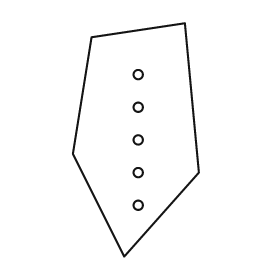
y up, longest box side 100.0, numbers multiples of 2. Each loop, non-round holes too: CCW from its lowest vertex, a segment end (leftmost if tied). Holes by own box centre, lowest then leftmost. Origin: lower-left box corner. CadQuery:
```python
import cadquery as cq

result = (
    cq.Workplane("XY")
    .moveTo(22.0, 0.0)
    .lineTo(54.0, 36.0)
    .lineTo(48.0, 100.0)
    .lineTo(8.0, 94.0)
    .lineTo(0.0, 44.0)
    .close()
    .moveTo(28.0, 22.0)
    .circle(2.0)
    .moveTo(28.0, 36.0)
    .circle(2.0)
    .moveTo(28.0, 50.0)
    .circle(2.0)
    .moveTo(28.0, 64.0)
    .circle(2.0)
    .moveTo(28.0, 78.0)
    .circle(2.0)
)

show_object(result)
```